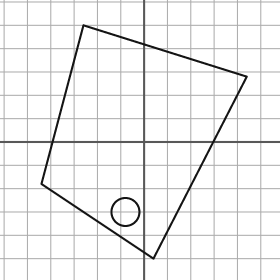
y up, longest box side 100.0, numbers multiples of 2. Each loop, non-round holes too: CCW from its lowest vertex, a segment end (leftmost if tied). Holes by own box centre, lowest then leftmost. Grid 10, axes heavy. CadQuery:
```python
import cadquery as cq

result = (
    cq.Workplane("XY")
    .moveTo(4.0, -50.0)
    .lineTo(44.0, 28.0)
    .lineTo(-26.0, 50.0)
    .lineTo(-44.0, -18.0)
    .close()
    .moveTo(-8.0, -30.0)
    .circle(6.0)
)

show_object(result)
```